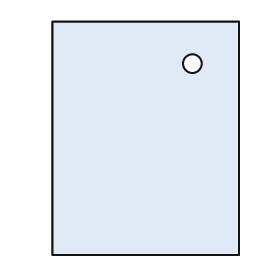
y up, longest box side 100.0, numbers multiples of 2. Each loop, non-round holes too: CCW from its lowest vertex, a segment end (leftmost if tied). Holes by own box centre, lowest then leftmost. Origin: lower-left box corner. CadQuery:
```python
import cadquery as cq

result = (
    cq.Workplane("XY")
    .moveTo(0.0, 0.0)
    .lineTo(80.0, 0.0)
    .lineTo(80.0, 100.0)
    .lineTo(0.0, 100.0)
    .close()
    .moveTo(60.0, 82.0)
    .circle(4.0)
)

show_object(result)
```